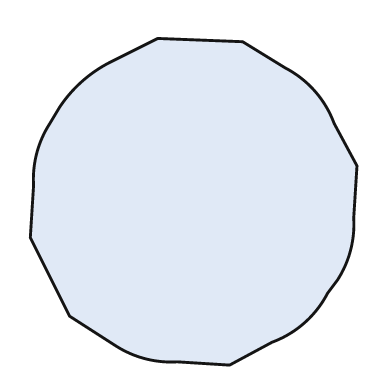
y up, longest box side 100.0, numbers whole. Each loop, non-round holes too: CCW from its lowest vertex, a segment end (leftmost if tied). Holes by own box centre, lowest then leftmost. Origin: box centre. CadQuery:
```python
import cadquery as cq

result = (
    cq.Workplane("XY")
    .moveTo(11.0, -50.0)
    .lineTo(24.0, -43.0)
    .threePointArc((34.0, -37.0), (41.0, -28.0))
    .lineTo(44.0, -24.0)
    .threePointArc((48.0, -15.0), (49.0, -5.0))
    .lineTo(50.0, 11.0)
    .lineTo(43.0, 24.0)
    .threePointArc((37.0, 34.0), (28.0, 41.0))
    .lineTo(15.0, 49.0)
    .lineTo(-11.0, 50.0)
    .lineTo(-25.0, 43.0)
    .threePointArc((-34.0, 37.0), (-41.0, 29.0))
    .lineTo(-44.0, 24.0)
    .threePointArc((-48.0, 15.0), (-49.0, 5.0))
    .lineTo(-50.0, -11.0)
    .lineTo(-38.0, -35.0)
    .lineTo(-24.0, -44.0)
    .threePointArc((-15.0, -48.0), (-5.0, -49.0))
    .close()
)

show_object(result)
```